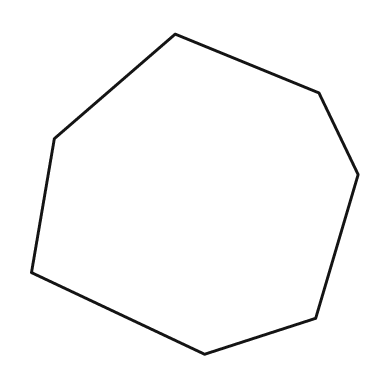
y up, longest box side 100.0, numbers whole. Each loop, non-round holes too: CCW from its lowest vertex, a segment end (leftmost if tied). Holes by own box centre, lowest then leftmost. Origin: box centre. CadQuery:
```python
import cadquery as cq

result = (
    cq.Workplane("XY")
    .moveTo(3.0, -49.0)
    .lineTo(37.0, -38.0)
    .lineTo(50.0, 6.0)
    .lineTo(38.0, 31.0)
    .lineTo(-6.0, 49.0)
    .lineTo(-43.0, 17.0)
    .lineTo(-50.0, -24.0)
    .close()
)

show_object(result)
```